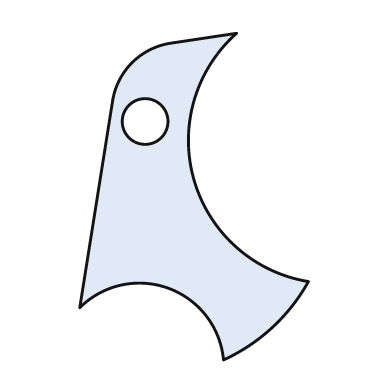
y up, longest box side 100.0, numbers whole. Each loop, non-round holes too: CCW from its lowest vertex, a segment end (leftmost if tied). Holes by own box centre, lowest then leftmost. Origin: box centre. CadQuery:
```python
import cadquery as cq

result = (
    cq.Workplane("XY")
    .moveTo(9.0, -50.0)
    .threePointArc((24.0, -40.0), (35.0, -26.0))
    .threePointArc((0.0, 5.0), (13.0, 50.0))
    .lineTo(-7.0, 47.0)
    .threePointArc((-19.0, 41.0), (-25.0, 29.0))
    .lineTo(-35.0, -34.0)
    .threePointArc((-8.0, -28.0), (9.0, -50.0))
    .close()
    .moveTo(-15.0, 23.0)
    .circle(7.0)
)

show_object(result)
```